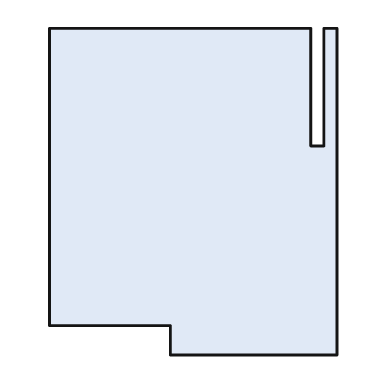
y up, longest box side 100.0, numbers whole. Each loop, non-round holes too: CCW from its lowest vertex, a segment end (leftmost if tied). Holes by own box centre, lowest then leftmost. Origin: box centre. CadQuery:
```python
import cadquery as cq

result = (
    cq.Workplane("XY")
    .moveTo(-7.0, -50.0)
    .lineTo(44.0, -50.0)
    .lineTo(44.0, 50.0)
    .lineTo(40.0, 50.0)
    .lineTo(40.0, 14.0)
    .lineTo(36.0, 14.0)
    .lineTo(36.0, 50.0)
    .lineTo(-44.0, 50.0)
    .lineTo(-44.0, -41.0)
    .lineTo(-7.0, -41.0)
    .close()
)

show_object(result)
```